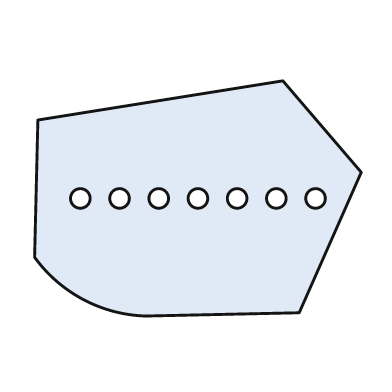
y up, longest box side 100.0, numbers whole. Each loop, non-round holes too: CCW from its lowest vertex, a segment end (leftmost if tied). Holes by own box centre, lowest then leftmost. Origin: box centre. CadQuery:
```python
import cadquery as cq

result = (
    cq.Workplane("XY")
    .moveTo(-16.0, -36.0)
    .lineTo(31.0, -35.0)
    .lineTo(50.0, 8.0)
    .lineTo(26.0, 36.0)
    .lineTo(-49.0, 24.0)
    .lineTo(-50.0, -18.0)
    .threePointArc((-35.0, -31.0), (-16.0, -36.0))
    .close()
    .moveTo(-36.0, 0.0)
    .circle(3.0)
    .moveTo(-24.0, 0.0)
    .circle(3.0)
    .moveTo(-12.0, 0.0)
    .circle(3.0)
    .moveTo(0.0, 0.0)
    .circle(3.0)
    .moveTo(12.0, 0.0)
    .circle(3.0)
    .moveTo(24.0, 0.0)
    .circle(3.0)
    .moveTo(36.0, 0.0)
    .circle(3.0)
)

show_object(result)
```